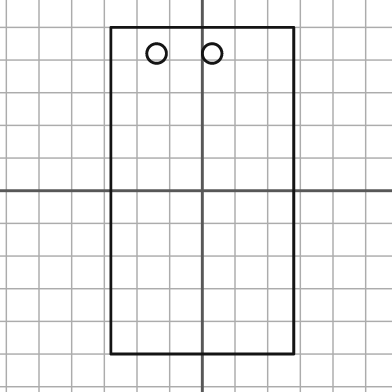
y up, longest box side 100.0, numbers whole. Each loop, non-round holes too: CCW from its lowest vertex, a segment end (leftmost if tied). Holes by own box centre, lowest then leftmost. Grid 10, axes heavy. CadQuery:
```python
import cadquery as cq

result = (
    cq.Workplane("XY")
    .moveTo(-28.0, -50.0)
    .lineTo(28.0, -50.0)
    .lineTo(28.0, 50.0)
    .lineTo(-28.0, 50.0)
    .close()
    .moveTo(-14.0, 42.0)
    .circle(3.0)
    .moveTo(3.0, 42.0)
    .circle(3.0)
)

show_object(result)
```